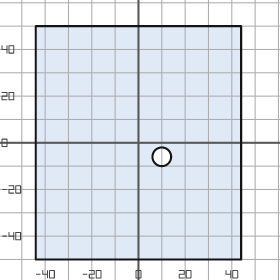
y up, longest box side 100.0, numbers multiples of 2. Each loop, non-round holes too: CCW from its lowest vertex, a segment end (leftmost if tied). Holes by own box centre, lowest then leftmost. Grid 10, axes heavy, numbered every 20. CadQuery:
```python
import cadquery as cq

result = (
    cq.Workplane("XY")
    .moveTo(-44.0, -50.0)
    .lineTo(44.0, -50.0)
    .lineTo(44.0, 50.0)
    .lineTo(-44.0, 50.0)
    .close()
    .moveTo(10.0, -6.0)
    .circle(4.0)
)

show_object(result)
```